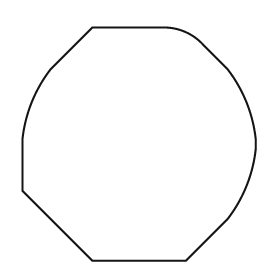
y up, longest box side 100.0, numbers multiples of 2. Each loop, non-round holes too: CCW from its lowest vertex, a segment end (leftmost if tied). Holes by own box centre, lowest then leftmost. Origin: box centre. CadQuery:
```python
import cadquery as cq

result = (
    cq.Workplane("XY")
    .moveTo(-20.0, -50.0)
    .lineTo(20.0, -50.0)
    .lineTo(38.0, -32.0)
    .threePointArc((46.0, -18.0), (50.0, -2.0))
    .lineTo(50.0, 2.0)
    .threePointArc((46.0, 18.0), (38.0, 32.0))
    .lineTo(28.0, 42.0)
    .threePointArc((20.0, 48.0), (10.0, 50.0))
    .lineTo(-20.0, 50.0)
    .lineTo(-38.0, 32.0)
    .threePointArc((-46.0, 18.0), (-50.0, 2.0))
    .lineTo(-50.0, -20.0)
    .close()
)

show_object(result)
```